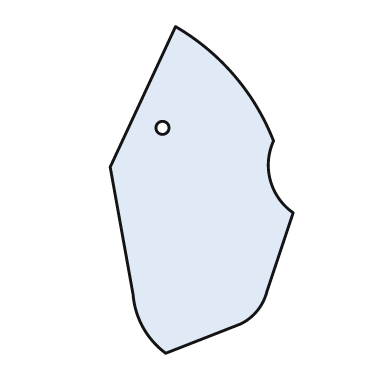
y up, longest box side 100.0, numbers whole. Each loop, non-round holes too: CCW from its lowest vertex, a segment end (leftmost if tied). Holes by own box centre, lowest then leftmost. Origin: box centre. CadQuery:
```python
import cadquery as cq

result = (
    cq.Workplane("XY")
    .moveTo(-11.0, -50.0)
    .lineTo(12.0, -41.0)
    .threePointArc((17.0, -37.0), (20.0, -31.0))
    .lineTo(28.0, -7.0)
    .threePointArc((21.0, 3.0), (22.0, 15.0))
    .threePointArc((10.0, 35.0), (-8.0, 50.0))
    .lineTo(-28.0, 7.0)
    .lineTo(-21.0, -32.0)
    .threePointArc((-18.0, -42.0), (-11.0, -50.0))
    .close()
    .moveTo(-12.0, 19.0)
    .circle(2.0)
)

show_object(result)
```